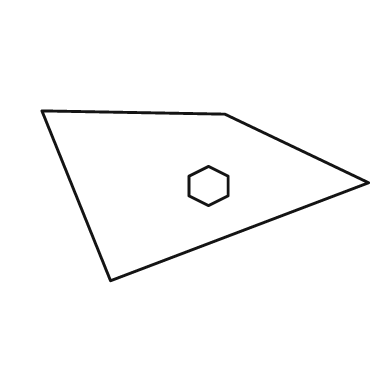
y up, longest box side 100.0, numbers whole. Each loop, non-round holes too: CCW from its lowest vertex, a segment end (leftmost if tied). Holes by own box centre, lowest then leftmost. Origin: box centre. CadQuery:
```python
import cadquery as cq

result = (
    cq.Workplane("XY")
    .moveTo(-29.0, -26.0)
    .lineTo(50.0, 4.0)
    .lineTo(6.0, 25.0)
    .lineTo(-50.0, 26.0)
    .close()
    .moveTo(1.0, -3.0)
    .lineTo(7.0, 0.0)
    .lineTo(7.0, 6.0)
    .lineTo(1.0, 9.0)
    .lineTo(-5.0, 6.0)
    .lineTo(-5.0, 0.0)
    .close()
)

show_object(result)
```